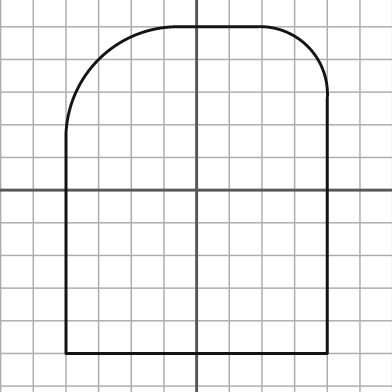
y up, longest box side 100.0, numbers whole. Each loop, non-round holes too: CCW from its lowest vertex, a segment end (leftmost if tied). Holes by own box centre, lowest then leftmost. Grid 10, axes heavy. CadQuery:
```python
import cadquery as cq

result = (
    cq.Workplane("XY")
    .moveTo(-40.0, -50.0)
    .lineTo(40.0, -50.0)
    .lineTo(40.0, 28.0)
    .threePointArc((34.0, 44.0), (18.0, 50.0))
    .lineTo(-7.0, 50.0)
    .threePointArc((-30.0, 40.0), (-40.0, 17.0))
    .close()
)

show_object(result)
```